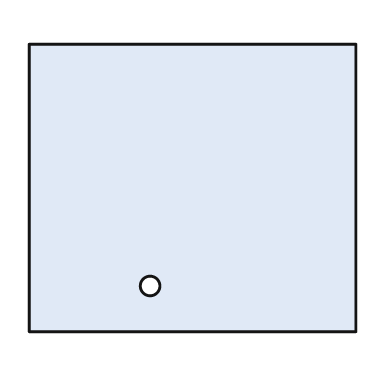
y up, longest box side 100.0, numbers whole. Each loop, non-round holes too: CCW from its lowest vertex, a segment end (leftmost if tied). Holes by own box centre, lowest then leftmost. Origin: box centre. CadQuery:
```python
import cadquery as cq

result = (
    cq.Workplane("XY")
    .moveTo(-50.0, -44.0)
    .lineTo(50.0, -44.0)
    .lineTo(50.0, 44.0)
    .lineTo(-50.0, 44.0)
    .close()
    .moveTo(-13.0, -30.0)
    .circle(3.0)
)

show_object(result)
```